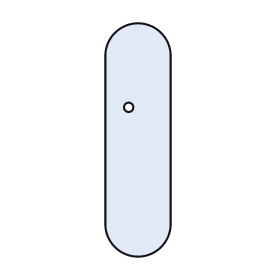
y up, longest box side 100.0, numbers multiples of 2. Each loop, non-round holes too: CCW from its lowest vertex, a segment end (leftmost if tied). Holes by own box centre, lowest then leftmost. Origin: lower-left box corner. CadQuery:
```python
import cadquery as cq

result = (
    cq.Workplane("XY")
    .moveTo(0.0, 14.0)
    .threePointArc((14.0, 0.0), (28.0, 14.0))
    .lineTo(28.0, 86.0)
    .threePointArc((14.0, 100.0), (0.0, 86.0))
    .close()
    .moveTo(10.0, 64.0)
    .circle(2.0)
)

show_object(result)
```